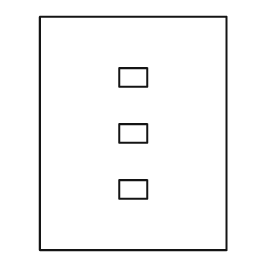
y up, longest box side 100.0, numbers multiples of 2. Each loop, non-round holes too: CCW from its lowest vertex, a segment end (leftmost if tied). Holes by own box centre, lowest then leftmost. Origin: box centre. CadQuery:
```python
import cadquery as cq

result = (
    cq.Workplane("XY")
    .moveTo(-40.0, -50.0)
    .lineTo(40.0, -50.0)
    .lineTo(40.0, 50.0)
    .lineTo(-40.0, 50.0)
    .close()
    .moveTo(-6.0, -28.0)
    .lineTo(6.0, -28.0)
    .lineTo(6.0, -20.0)
    .lineTo(-6.0, -20.0)
    .close()
    .moveTo(-6.0, -4.0)
    .lineTo(6.0, -4.0)
    .lineTo(6.0, 4.0)
    .lineTo(-6.0, 4.0)
    .close()
    .moveTo(-6.0, 20.0)
    .lineTo(6.0, 20.0)
    .lineTo(6.0, 28.0)
    .lineTo(-6.0, 28.0)
    .close()
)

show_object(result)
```